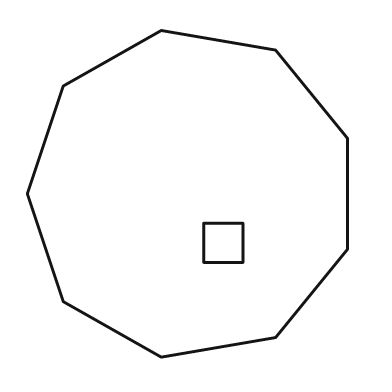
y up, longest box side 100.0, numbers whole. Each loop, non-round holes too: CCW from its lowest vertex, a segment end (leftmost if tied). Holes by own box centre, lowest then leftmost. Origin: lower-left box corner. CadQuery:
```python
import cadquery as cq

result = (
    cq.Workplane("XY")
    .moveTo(41.0, 0.0)
    .lineTo(76.0, 6.0)
    .lineTo(98.0, 33.0)
    .lineTo(98.0, 67.0)
    .lineTo(76.0, 94.0)
    .lineTo(41.0, 100.0)
    .lineTo(11.0, 83.0)
    .lineTo(0.0, 50.0)
    .lineTo(11.0, 17.0)
    .close()
    .moveTo(54.0, 29.0)
    .lineTo(66.0, 29.0)
    .lineTo(66.0, 41.0)
    .lineTo(54.0, 41.0)
    .close()
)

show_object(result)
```